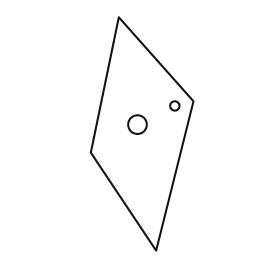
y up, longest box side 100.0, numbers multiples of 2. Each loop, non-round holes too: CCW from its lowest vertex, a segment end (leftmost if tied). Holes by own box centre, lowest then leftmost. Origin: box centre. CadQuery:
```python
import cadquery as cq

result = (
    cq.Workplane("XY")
    .moveTo(6.0, -50.0)
    .lineTo(22.0, 14.0)
    .lineTo(-10.0, 50.0)
    .lineTo(-22.0, -8.0)
    .close()
    .moveTo(-2.0, 4.0)
    .circle(4.0)
    .moveTo(14.0, 12.0)
    .circle(2.0)
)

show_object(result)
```